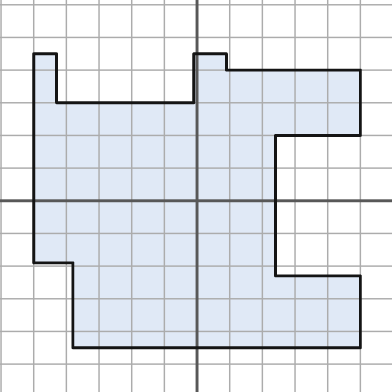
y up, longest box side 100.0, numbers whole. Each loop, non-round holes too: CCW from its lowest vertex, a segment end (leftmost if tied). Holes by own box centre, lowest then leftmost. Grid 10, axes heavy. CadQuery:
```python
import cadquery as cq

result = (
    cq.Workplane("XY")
    .moveTo(-38.0, -45.0)
    .lineTo(50.0, -45.0)
    .lineTo(50.0, -23.0)
    .lineTo(24.0, -23.0)
    .lineTo(24.0, 20.0)
    .lineTo(50.0, 20.0)
    .lineTo(50.0, 40.0)
    .lineTo(9.0, 40.0)
    .lineTo(9.0, 45.0)
    .lineTo(-1.0, 45.0)
    .lineTo(-1.0, 30.0)
    .lineTo(-43.0, 30.0)
    .lineTo(-43.0, 45.0)
    .lineTo(-50.0, 45.0)
    .lineTo(-50.0, -19.0)
    .lineTo(-38.0, -19.0)
    .close()
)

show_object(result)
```